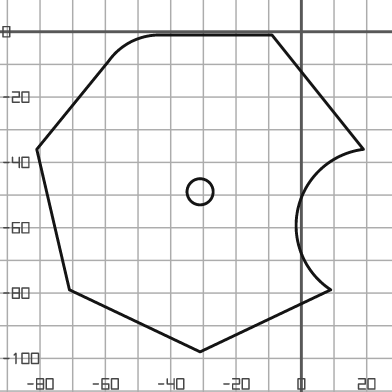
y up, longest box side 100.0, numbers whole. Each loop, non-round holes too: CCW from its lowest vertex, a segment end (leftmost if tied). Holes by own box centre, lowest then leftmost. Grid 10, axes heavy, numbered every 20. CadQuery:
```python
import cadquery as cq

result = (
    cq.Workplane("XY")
    .moveTo(-31.0, -98.0)
    .lineTo(9.0, -79.0)
    .threePointArc((-1.0, -54.0), (19.0, -36.0))
    .lineTo(-9.0, -1.0)
    .lineTo(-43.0, -1.0)
    .threePointArc((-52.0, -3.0), (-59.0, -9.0))
    .lineTo(-81.0, -36.0)
    .lineTo(-71.0, -79.0)
    .close()
    .moveTo(-31.0, -49.0)
    .circle(4.0)
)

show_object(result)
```